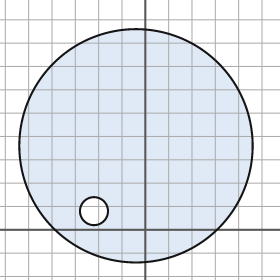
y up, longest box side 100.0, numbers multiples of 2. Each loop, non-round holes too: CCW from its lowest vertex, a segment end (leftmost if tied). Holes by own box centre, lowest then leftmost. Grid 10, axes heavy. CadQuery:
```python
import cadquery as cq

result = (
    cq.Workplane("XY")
    .moveTo(-4.0, 36.0)
    .circle(50.0)
    .moveTo(-22.0, 8.0)
    .circle(6.0)
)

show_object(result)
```